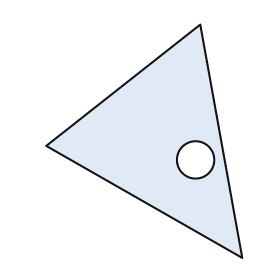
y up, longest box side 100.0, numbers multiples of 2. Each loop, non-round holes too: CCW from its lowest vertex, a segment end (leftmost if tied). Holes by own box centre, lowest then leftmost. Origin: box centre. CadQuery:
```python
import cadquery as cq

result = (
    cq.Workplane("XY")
    .moveTo(42.0, -50.0)
    .lineTo(24.0, 50.0)
    .lineTo(-42.0, -2.0)
    .close()
    .moveTo(22.0, -8.0)
    .circle(8.0)
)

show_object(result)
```